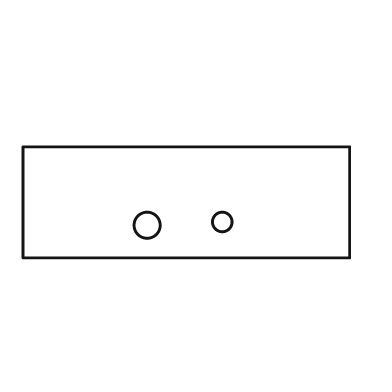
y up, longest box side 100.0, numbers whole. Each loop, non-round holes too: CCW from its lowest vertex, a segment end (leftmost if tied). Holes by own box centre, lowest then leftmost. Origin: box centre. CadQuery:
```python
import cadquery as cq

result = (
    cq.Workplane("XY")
    .moveTo(-50.0, -17.0)
    .lineTo(50.0, -17.0)
    .lineTo(50.0, 17.0)
    .lineTo(-50.0, 17.0)
    .close()
    .moveTo(-12.0, -7.0)
    .circle(4.0)
    .moveTo(11.0, -6.0)
    .circle(3.0)
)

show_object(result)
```